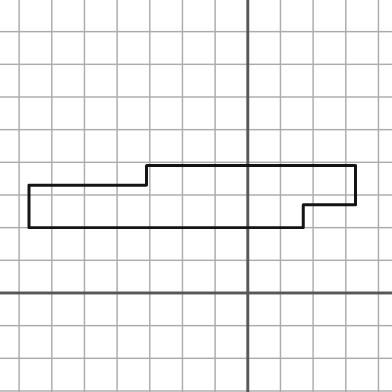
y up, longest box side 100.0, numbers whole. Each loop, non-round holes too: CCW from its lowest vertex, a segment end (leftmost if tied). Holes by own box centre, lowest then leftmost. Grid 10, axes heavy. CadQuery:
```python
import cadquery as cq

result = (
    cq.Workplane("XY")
    .moveTo(-67.0, 20.0)
    .lineTo(17.0, 20.0)
    .lineTo(17.0, 27.0)
    .lineTo(33.0, 27.0)
    .lineTo(33.0, 39.0)
    .lineTo(-31.0, 39.0)
    .lineTo(-31.0, 33.0)
    .lineTo(-67.0, 33.0)
    .close()
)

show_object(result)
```